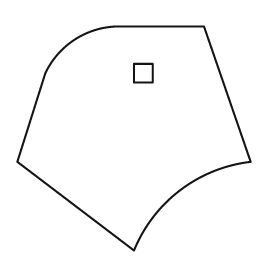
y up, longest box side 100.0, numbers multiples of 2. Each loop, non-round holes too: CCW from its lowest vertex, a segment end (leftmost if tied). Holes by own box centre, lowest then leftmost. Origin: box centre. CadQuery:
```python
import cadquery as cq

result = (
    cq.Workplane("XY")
    .moveTo(0.0, -48.0)
    .threePointArc((20.0, -22.0), (50.0, -10.0))
    .lineTo(30.0, 48.0)
    .lineTo(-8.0, 48.0)
    .threePointArc((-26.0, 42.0), (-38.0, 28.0))
    .lineTo(-50.0, -10.0)
    .close()
    .moveTo(0.0, 24.0)
    .lineTo(8.0, 24.0)
    .lineTo(8.0, 32.0)
    .lineTo(0.0, 32.0)
    .close()
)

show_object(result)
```